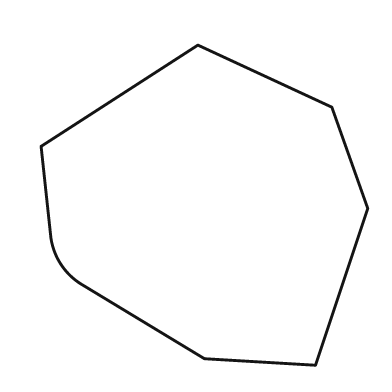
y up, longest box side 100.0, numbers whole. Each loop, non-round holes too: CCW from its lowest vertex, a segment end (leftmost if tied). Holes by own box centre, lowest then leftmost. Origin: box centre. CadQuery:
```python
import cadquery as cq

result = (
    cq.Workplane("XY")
    .moveTo(34.0, -49.0)
    .lineTo(50.0, -1.0)
    .lineTo(39.0, 30.0)
    .lineTo(-2.0, 49.0)
    .lineTo(-50.0, 18.0)
    .lineTo(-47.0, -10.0)
    .threePointArc((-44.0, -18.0), (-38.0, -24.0))
    .lineTo(0.0, -47.0)
    .close()
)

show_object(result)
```